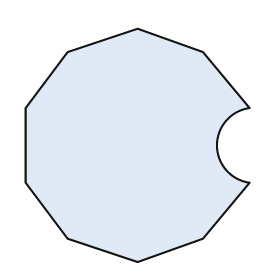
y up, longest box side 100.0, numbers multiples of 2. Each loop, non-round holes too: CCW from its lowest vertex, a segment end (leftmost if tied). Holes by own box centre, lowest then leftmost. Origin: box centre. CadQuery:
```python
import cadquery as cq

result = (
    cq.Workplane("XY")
    .moveTo(0.0, -50.0)
    .lineTo(28.0, -40.0)
    .lineTo(48.0, -16.0)
    .threePointArc((34.0, 0.0), (48.0, 16.0))
    .lineTo(28.0, 40.0)
    .lineTo(0.0, 50.0)
    .lineTo(-30.0, 40.0)
    .lineTo(-48.0, 16.0)
    .lineTo(-48.0, -16.0)
    .lineTo(-30.0, -40.0)
    .close()
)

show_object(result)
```